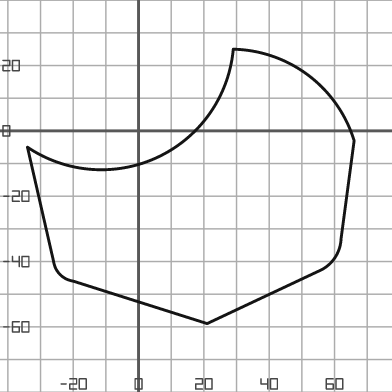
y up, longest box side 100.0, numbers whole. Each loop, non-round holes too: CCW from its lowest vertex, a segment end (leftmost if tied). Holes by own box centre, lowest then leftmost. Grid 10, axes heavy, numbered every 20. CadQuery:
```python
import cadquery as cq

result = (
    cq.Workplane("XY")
    .moveTo(21.0, -59.0)
    .lineTo(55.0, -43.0)
    .threePointArc((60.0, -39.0), (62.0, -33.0))
    .lineTo(66.0, -3.0)
    .threePointArc((52.0, 17.0), (29.0, 25.0))
    .threePointArc((6.0, -8.0), (-34.0, -5.0))
    .lineTo(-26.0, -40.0)
    .threePointArc((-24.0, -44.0), (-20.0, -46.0))
    .close()
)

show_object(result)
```